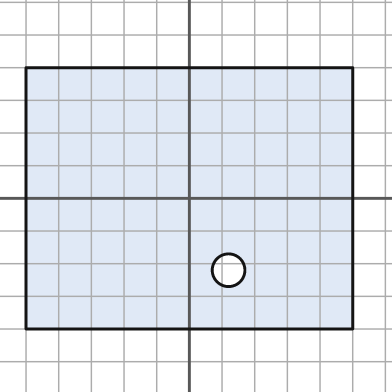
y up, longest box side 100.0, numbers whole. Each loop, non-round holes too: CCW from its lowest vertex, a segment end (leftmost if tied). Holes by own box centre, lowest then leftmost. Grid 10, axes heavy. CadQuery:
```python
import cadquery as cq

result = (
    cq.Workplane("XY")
    .moveTo(-50.0, -40.0)
    .lineTo(50.0, -40.0)
    .lineTo(50.0, 40.0)
    .lineTo(-50.0, 40.0)
    .close()
    .moveTo(12.0, -22.0)
    .circle(5.0)
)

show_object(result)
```